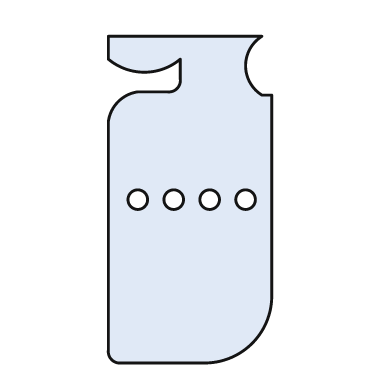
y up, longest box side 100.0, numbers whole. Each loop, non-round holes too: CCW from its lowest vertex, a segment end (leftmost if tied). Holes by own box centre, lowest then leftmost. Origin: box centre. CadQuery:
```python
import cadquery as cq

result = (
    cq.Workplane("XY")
    .moveTo(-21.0, -50.0)
    .lineTo(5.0, -50.0)
    .threePointArc((19.0, -44.0), (25.0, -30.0))
    .lineTo(25.0, 32.0)
    .lineTo(22.0, 32.0)
    .threePointArc((17.0, 41.0), (22.0, 50.0))
    .lineTo(-25.0, 50.0)
    .lineTo(-25.0, 43.0)
    .threePointArc((-14.0, 39.0), (-3.0, 43.0))
    .lineTo(-3.0, 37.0)
    .threePointArc((-4.0, 34.0), (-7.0, 33.0))
    .lineTo(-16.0, 33.0)
    .threePointArc((-22.0, 30.0), (-25.0, 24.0))
    .lineTo(-25.0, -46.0)
    .threePointArc((-24.0, -49.0), (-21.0, -50.0))
    .close()
    .moveTo(-16.0, 0.0)
    .circle(3.0)
    .moveTo(-5.0, 0.0)
    .circle(3.0)
    .moveTo(6.0, 0.0)
    .circle(3.0)
    .moveTo(17.0, 0.0)
    .circle(3.0)
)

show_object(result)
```